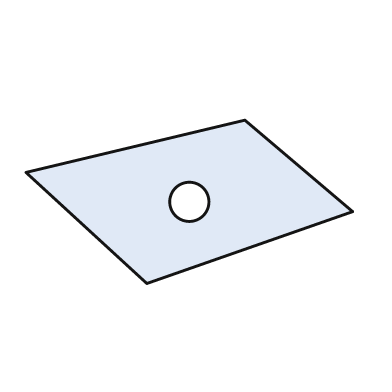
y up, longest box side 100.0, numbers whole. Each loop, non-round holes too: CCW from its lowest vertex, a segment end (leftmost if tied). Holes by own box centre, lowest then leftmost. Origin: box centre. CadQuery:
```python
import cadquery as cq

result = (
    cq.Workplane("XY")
    .moveTo(-13.0, -25.0)
    .lineTo(50.0, -3.0)
    .lineTo(17.0, 25.0)
    .lineTo(-50.0, 9.0)
    .close()
    .moveTo(0.0, 0.0)
    .circle(6.0)
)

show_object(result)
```